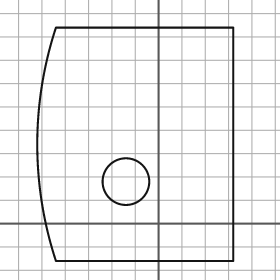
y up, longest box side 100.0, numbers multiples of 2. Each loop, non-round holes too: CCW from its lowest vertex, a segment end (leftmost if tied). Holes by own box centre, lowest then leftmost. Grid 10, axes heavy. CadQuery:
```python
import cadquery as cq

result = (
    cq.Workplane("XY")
    .moveTo(-44.0, -16.0)
    .lineTo(32.0, -16.0)
    .lineTo(32.0, 84.0)
    .lineTo(-44.0, 84.0)
    .threePointArc((-52.0, 34.0), (-44.0, -16.0))
    .close()
    .moveTo(-14.0, 18.0)
    .circle(10.0)
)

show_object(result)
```